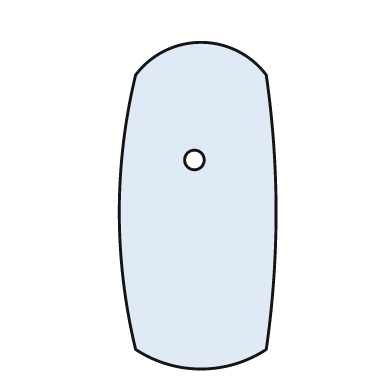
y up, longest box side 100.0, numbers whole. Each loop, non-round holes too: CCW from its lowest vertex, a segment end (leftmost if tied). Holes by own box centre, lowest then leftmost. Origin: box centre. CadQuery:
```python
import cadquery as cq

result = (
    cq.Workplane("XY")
    .moveTo(-19.0, -44.0)
    .threePointArc((1.0, -50.0), (21.0, -44.0))
    .threePointArc((24.0, -2.0), (21.0, 40.0))
    .threePointArc((1.0, 50.0), (-19.0, 40.0))
    .threePointArc((-24.0, -2.0), (-19.0, -44.0))
    .close()
    .moveTo(-1.0, 14.0)
    .circle(3.0)
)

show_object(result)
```